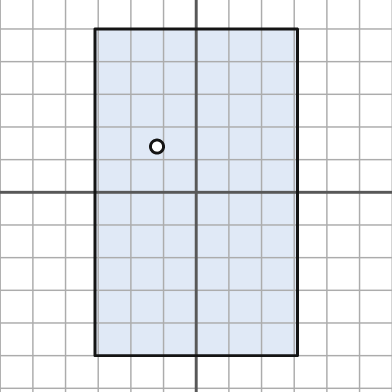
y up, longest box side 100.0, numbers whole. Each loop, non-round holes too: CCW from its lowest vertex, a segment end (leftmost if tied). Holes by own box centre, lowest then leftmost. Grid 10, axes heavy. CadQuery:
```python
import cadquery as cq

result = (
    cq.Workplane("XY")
    .moveTo(-31.0, -50.0)
    .lineTo(31.0, -50.0)
    .lineTo(31.0, 50.0)
    .lineTo(-31.0, 50.0)
    .close()
    .moveTo(-12.0, 14.0)
    .circle(2.0)
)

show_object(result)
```